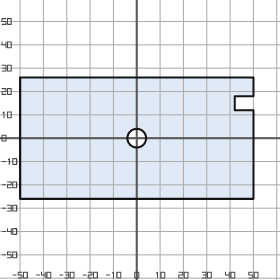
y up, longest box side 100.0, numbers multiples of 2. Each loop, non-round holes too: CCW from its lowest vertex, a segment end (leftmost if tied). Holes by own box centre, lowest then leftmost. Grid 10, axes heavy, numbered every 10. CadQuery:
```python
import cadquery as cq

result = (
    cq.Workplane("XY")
    .moveTo(-50.0, -26.0)
    .lineTo(50.0, -26.0)
    .lineTo(50.0, 12.0)
    .lineTo(42.0, 12.0)
    .lineTo(42.0, 18.0)
    .lineTo(50.0, 18.0)
    .lineTo(50.0, 26.0)
    .lineTo(-50.0, 26.0)
    .close()
    .moveTo(0.0, 0.0)
    .circle(4.0)
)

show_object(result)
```